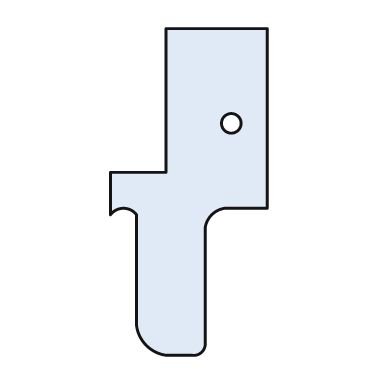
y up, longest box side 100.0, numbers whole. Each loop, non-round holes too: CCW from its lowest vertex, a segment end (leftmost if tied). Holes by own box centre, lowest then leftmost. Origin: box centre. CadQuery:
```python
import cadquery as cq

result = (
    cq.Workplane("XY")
    .moveTo(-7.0, -50.0)
    .lineTo(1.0, -50.0)
    .threePointArc((4.0, -49.0), (5.0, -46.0))
    .lineTo(5.0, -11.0)
    .threePointArc((7.0, -7.0), (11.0, -5.0))
    .lineTo(24.0, -5.0)
    .lineTo(24.0, 50.0)
    .lineTo(-7.0, 50.0)
    .lineTo(-7.0, 6.0)
    .lineTo(-24.0, 6.0)
    .lineTo(-24.0, -7.0)
    .threePointArc((-20.0, -5.0), (-16.0, -7.0))
    .lineTo(-16.0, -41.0)
    .threePointArc((-13.0, -47.0), (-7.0, -50.0))
    .close()
    .moveTo(13.0, 21.0)
    .circle(3.0)
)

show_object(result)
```